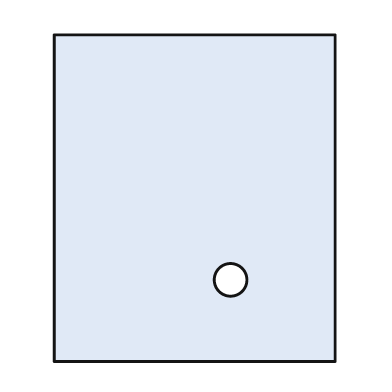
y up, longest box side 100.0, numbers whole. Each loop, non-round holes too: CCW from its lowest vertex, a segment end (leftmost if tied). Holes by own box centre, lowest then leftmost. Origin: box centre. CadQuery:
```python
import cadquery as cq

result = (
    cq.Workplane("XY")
    .moveTo(-43.0, -50.0)
    .lineTo(43.0, -50.0)
    .lineTo(43.0, 50.0)
    .lineTo(-43.0, 50.0)
    .close()
    .moveTo(11.0, -25.0)
    .circle(5.0)
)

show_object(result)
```